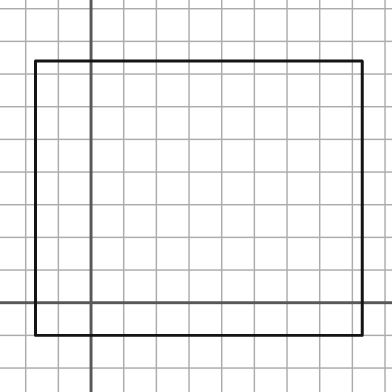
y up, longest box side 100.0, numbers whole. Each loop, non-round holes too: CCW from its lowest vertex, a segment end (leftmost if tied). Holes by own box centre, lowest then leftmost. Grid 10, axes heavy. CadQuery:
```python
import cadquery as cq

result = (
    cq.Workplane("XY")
    .moveTo(-17.0, -10.0)
    .lineTo(83.0, -10.0)
    .lineTo(83.0, 74.0)
    .lineTo(-17.0, 74.0)
    .close()
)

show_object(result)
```